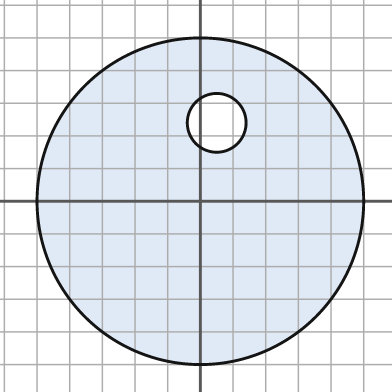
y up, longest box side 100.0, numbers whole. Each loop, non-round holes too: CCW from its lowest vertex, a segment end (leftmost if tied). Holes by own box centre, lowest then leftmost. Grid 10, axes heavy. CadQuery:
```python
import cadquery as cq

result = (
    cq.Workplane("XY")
    .moveTo(0.0, 0.0)
    .circle(50.0)
    .moveTo(5.0, 24.0)
    .circle(9.0)
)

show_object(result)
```